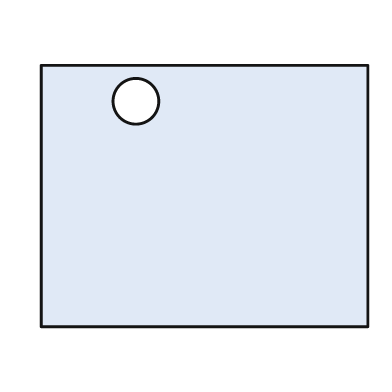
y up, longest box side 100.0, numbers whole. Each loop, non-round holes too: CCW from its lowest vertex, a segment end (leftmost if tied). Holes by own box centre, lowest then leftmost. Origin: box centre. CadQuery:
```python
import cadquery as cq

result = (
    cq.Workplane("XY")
    .moveTo(-50.0, -40.0)
    .lineTo(50.0, -40.0)
    .lineTo(50.0, 40.0)
    .lineTo(-50.0, 40.0)
    .close()
    .moveTo(-21.0, 29.0)
    .circle(7.0)
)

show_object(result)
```